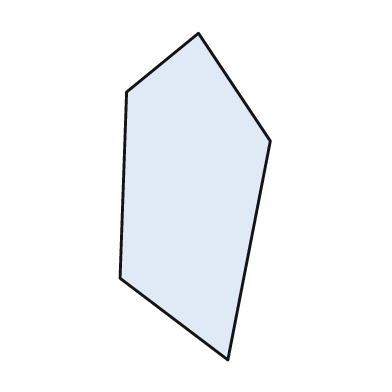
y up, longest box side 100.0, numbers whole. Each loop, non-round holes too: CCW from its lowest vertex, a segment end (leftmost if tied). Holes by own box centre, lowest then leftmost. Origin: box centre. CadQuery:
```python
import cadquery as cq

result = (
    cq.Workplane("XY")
    .moveTo(10.0, -50.0)
    .lineTo(23.0, 17.0)
    .lineTo(1.0, 50.0)
    .lineTo(-21.0, 32.0)
    .lineTo(-23.0, -25.0)
    .close()
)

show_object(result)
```